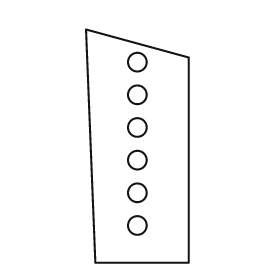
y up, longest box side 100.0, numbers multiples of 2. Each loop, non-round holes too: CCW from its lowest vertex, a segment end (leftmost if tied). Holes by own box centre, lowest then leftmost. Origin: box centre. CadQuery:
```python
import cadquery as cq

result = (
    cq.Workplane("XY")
    .moveTo(-18.0, -50.0)
    .lineTo(22.0, -50.0)
    .lineTo(22.0, 38.0)
    .lineTo(-22.0, 50.0)
    .close()
    .moveTo(0.0, -34.0)
    .circle(4.0)
    .moveTo(0.0, -20.0)
    .circle(4.0)
    .moveTo(0.0, -6.0)
    .circle(4.0)
    .moveTo(0.0, 8.0)
    .circle(4.0)
    .moveTo(0.0, 22.0)
    .circle(4.0)
    .moveTo(0.0, 36.0)
    .circle(4.0)
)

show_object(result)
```